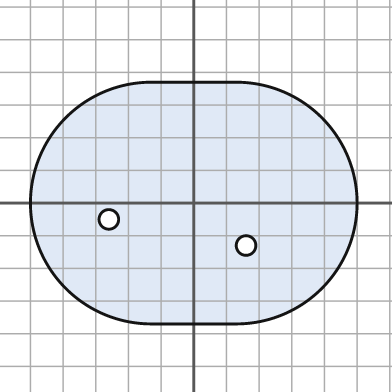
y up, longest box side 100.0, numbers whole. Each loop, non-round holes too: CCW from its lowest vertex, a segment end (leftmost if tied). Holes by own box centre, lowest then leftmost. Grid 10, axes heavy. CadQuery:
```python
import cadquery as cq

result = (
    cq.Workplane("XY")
    .moveTo(-13.0, -37.0)
    .lineTo(13.0, -37.0)
    .threePointArc((50.0, 0.0), (13.0, 37.0))
    .lineTo(-13.0, 37.0)
    .threePointArc((-50.0, 0.0), (-13.0, -37.0))
    .close()
    .moveTo(16.0, -13.0)
    .circle(3.0)
    .moveTo(-26.0, -5.0)
    .circle(3.0)
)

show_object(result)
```